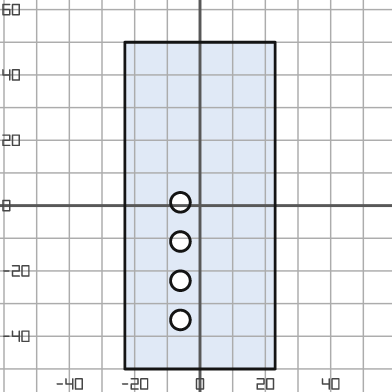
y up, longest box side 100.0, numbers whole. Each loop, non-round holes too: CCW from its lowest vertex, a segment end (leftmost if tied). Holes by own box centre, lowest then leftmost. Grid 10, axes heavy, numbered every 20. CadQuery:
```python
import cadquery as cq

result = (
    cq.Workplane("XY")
    .moveTo(-23.0, -50.0)
    .lineTo(23.0, -50.0)
    .lineTo(23.0, 50.0)
    .lineTo(-23.0, 50.0)
    .close()
    .moveTo(-6.0, -35.0)
    .circle(3.0)
    .moveTo(-6.0, -23.0)
    .circle(3.0)
    .moveTo(-6.0, -11.0)
    .circle(3.0)
    .moveTo(-6.0, 1.0)
    .circle(3.0)
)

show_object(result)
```